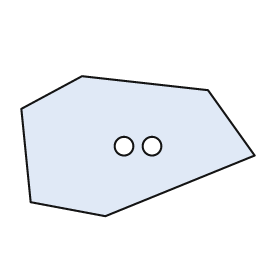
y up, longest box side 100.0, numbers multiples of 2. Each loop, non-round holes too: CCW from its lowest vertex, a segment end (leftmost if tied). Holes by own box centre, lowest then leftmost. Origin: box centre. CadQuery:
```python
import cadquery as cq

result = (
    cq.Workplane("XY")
    .moveTo(-14.0, -30.0)
    .lineTo(50.0, -4.0)
    .lineTo(30.0, 24.0)
    .lineTo(-24.0, 30.0)
    .lineTo(-50.0, 16.0)
    .lineTo(-46.0, -24.0)
    .close()
    .moveTo(-6.0, 0.0)
    .circle(4.0)
    .moveTo(6.0, 0.0)
    .circle(4.0)
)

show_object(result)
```